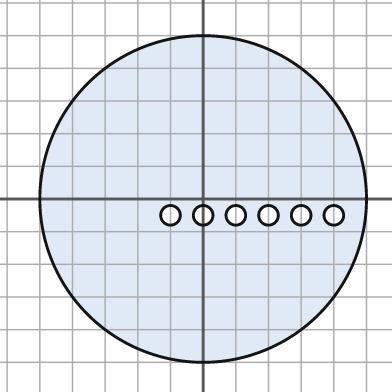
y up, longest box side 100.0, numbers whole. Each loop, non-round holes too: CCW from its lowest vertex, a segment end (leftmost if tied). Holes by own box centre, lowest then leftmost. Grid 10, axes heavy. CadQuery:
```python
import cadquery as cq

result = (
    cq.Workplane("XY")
    .moveTo(0.0, 0.0)
    .circle(50.0)
    .moveTo(-10.0, -5.0)
    .circle(3.0)
    .moveTo(0.0, -5.0)
    .circle(3.0)
    .moveTo(10.0, -5.0)
    .circle(3.0)
    .moveTo(20.0, -5.0)
    .circle(3.0)
    .moveTo(30.0, -5.0)
    .circle(3.0)
    .moveTo(40.0, -5.0)
    .circle(3.0)
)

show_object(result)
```